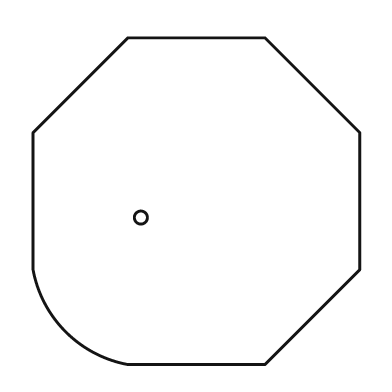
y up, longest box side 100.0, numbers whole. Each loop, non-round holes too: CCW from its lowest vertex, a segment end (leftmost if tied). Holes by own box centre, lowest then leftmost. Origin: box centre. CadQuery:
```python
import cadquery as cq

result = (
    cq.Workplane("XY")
    .moveTo(-21.0, -50.0)
    .lineTo(21.0, -50.0)
    .lineTo(50.0, -21.0)
    .lineTo(50.0, 21.0)
    .lineTo(21.0, 50.0)
    .lineTo(-21.0, 50.0)
    .lineTo(-50.0, 21.0)
    .lineTo(-50.0, -21.0)
    .threePointArc((-40.0, -40.0), (-21.0, -50.0))
    .close()
    .moveTo(-17.0, -5.0)
    .circle(2.0)
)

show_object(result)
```